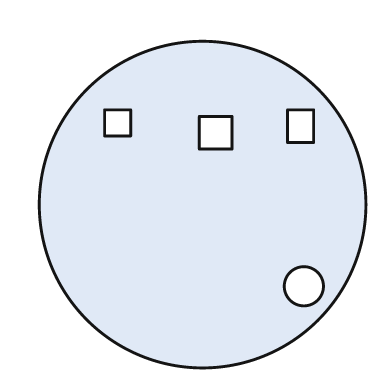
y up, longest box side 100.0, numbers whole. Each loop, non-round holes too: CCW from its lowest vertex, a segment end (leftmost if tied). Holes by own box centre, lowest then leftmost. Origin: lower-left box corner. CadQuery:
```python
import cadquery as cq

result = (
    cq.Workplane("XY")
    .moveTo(50.0, 50.0)
    .circle(50.0)
    .moveTo(81.0, 25.0)
    .circle(6.0)
    .moveTo(49.0, 67.0)
    .lineTo(59.0, 67.0)
    .lineTo(59.0, 77.0)
    .lineTo(49.0, 77.0)
    .close()
    .moveTo(76.0, 69.0)
    .lineTo(84.0, 69.0)
    .lineTo(84.0, 79.0)
    .lineTo(76.0, 79.0)
    .close()
    .moveTo(20.0, 71.0)
    .lineTo(28.0, 71.0)
    .lineTo(28.0, 79.0)
    .lineTo(20.0, 79.0)
    .close()
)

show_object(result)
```